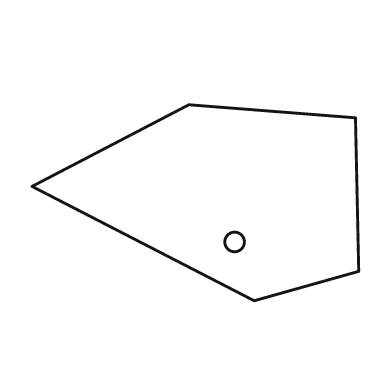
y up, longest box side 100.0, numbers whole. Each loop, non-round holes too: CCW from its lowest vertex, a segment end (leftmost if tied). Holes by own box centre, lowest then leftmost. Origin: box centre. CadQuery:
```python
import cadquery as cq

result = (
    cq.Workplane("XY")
    .moveTo(18.0, -30.0)
    .lineTo(50.0, -21.0)
    .lineTo(49.0, 26.0)
    .lineTo(-2.0, 30.0)
    .lineTo(-50.0, 5.0)
    .close()
    .moveTo(12.0, -12.0)
    .circle(3.0)
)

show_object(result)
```